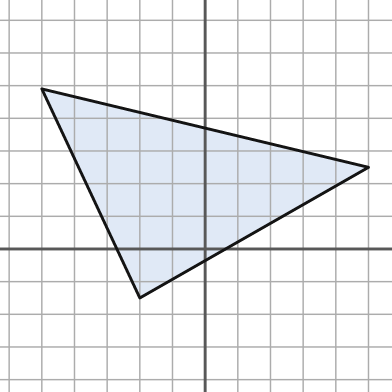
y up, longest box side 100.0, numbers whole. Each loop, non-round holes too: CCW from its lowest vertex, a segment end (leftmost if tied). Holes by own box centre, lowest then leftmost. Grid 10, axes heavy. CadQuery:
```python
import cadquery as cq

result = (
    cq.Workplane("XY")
    .moveTo(-20.0, -15.0)
    .lineTo(50.0, 25.0)
    .lineTo(-50.0, 49.0)
    .close()
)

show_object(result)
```